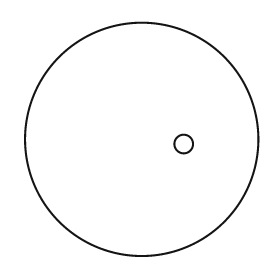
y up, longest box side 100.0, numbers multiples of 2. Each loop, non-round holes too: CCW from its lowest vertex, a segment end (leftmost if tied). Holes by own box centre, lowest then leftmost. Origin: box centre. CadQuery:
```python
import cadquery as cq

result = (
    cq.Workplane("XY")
    .moveTo(0.0, 0.0)
    .circle(50.0)
    .moveTo(18.0, -2.0)
    .circle(4.0)
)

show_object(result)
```